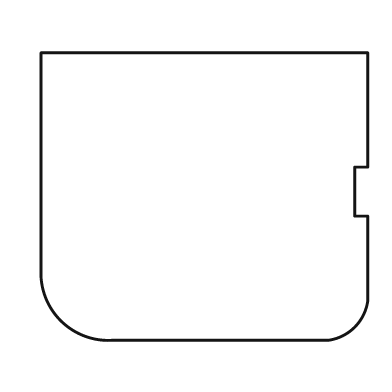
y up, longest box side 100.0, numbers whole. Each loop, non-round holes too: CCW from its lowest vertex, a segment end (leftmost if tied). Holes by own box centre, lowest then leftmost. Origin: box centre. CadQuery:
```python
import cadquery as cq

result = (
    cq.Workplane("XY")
    .moveTo(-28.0, -44.0)
    .lineTo(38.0, -44.0)
    .threePointArc((46.0, -40.0), (50.0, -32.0))
    .lineTo(50.0, -6.0)
    .lineTo(46.0, -6.0)
    .lineTo(46.0, 9.0)
    .lineTo(50.0, 9.0)
    .lineTo(50.0, 44.0)
    .lineTo(-50.0, 44.0)
    .lineTo(-50.0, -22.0)
    .threePointArc((-44.0, -38.0), (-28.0, -44.0))
    .close()
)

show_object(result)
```